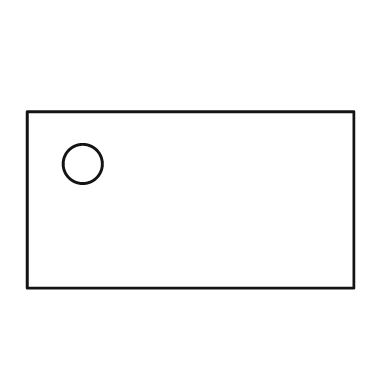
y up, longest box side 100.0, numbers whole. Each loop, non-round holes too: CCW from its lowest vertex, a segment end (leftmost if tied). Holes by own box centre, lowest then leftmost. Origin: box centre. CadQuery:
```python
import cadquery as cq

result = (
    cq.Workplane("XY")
    .moveTo(-50.0, -27.0)
    .lineTo(50.0, -27.0)
    .lineTo(50.0, 27.0)
    .lineTo(-50.0, 27.0)
    .close()
    .moveTo(-33.0, 11.0)
    .circle(6.0)
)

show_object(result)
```